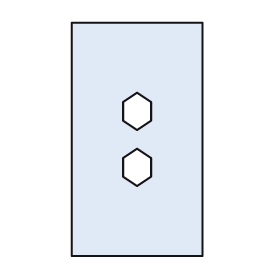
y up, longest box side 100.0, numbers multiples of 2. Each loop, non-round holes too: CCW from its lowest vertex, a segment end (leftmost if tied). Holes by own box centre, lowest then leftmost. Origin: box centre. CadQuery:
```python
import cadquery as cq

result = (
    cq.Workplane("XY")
    .moveTo(-28.0, -50.0)
    .lineTo(28.0, -50.0)
    .lineTo(28.0, 50.0)
    .lineTo(-28.0, 50.0)
    .close()
    .moveTo(0.0, -20.0)
    .lineTo(6.0, -16.0)
    .lineTo(6.0, -8.0)
    .lineTo(0.0, -4.0)
    .lineTo(-6.0, -8.0)
    .lineTo(-6.0, -16.0)
    .close()
    .moveTo(0.0, 4.0)
    .lineTo(6.0, 8.0)
    .lineTo(6.0, 16.0)
    .lineTo(0.0, 20.0)
    .lineTo(-6.0, 16.0)
    .lineTo(-6.0, 8.0)
    .close()
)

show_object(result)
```